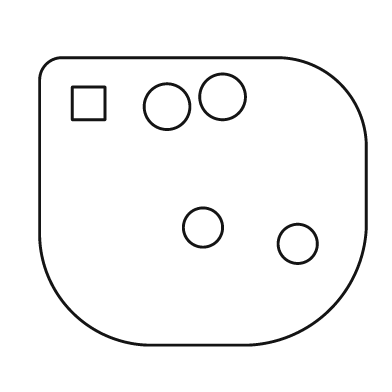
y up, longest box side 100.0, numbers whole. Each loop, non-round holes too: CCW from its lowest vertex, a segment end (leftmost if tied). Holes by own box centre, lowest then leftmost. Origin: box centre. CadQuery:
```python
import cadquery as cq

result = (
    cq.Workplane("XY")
    .moveTo(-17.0, -44.0)
    .lineTo(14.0, -44.0)
    .threePointArc((39.0, -33.0), (50.0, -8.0))
    .lineTo(50.0, 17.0)
    .threePointArc((42.0, 36.0), (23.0, 44.0))
    .lineTo(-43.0, 44.0)
    .threePointArc((-48.0, 42.0), (-50.0, 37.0))
    .lineTo(-50.0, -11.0)
    .threePointArc((-40.0, -34.0), (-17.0, -44.0))
    .close()
    .moveTo(29.0, -13.0)
    .circle(6.0)
    .moveTo(0.0, -8.0)
    .circle(6.0)
    .moveTo(-11.0, 29.0)
    .circle(7.0)
    .moveTo(-40.0, 25.0)
    .lineTo(-30.0, 25.0)
    .lineTo(-30.0, 35.0)
    .lineTo(-40.0, 35.0)
    .close()
    .moveTo(6.0, 32.0)
    .circle(7.0)
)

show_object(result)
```